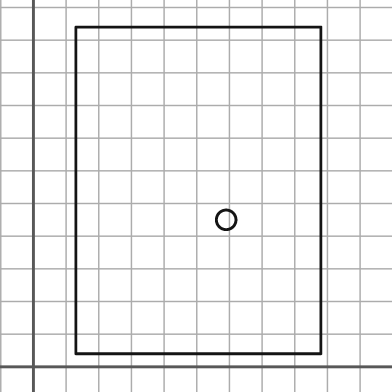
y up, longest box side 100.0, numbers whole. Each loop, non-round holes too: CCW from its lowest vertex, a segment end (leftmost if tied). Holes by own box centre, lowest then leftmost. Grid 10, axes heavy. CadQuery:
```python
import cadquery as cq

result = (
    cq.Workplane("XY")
    .moveTo(13.0, 4.0)
    .lineTo(88.0, 4.0)
    .lineTo(88.0, 104.0)
    .lineTo(13.0, 104.0)
    .close()
    .moveTo(59.0, 45.0)
    .circle(3.0)
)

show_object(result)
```